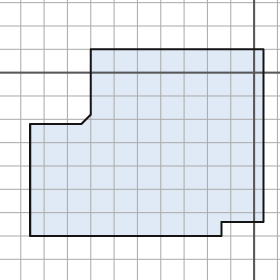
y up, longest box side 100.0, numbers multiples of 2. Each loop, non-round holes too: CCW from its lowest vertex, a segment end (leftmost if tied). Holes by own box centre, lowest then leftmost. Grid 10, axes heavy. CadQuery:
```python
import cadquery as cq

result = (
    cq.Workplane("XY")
    .moveTo(-96.0, -70.0)
    .lineTo(-14.0, -70.0)
    .lineTo(-14.0, -64.0)
    .lineTo(4.0, -64.0)
    .lineTo(4.0, 10.0)
    .lineTo(-70.0, 10.0)
    .lineTo(-70.0, -18.0)
    .lineTo(-74.0, -22.0)
    .lineTo(-96.0, -22.0)
    .close()
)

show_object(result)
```